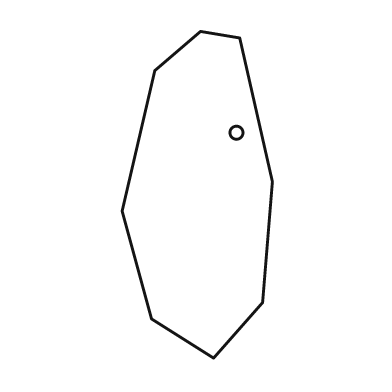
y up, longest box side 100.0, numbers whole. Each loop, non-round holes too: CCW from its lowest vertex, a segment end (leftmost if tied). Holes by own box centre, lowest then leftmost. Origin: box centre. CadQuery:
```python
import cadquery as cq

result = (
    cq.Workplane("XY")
    .moveTo(5.0, -50.0)
    .lineTo(20.0, -33.0)
    .lineTo(23.0, 4.0)
    .lineTo(13.0, 48.0)
    .lineTo(1.0, 50.0)
    .lineTo(-13.0, 38.0)
    .lineTo(-23.0, -5.0)
    .lineTo(-14.0, -38.0)
    .close()
    .moveTo(12.0, 19.0)
    .circle(2.0)
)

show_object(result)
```